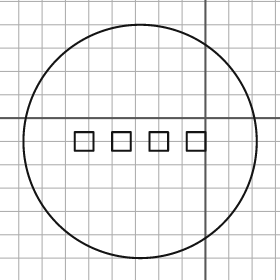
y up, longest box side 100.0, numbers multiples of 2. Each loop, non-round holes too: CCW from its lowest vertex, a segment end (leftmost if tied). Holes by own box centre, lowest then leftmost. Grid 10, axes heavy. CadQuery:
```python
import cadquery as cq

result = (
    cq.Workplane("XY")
    .moveTo(-28.0, -10.0)
    .circle(50.0)
    .moveTo(-56.0, -14.0)
    .lineTo(-48.0, -14.0)
    .lineTo(-48.0, -6.0)
    .lineTo(-56.0, -6.0)
    .close()
    .moveTo(-40.0, -14.0)
    .lineTo(-32.0, -14.0)
    .lineTo(-32.0, -6.0)
    .lineTo(-40.0, -6.0)
    .close()
    .moveTo(-24.0, -14.0)
    .lineTo(-16.0, -14.0)
    .lineTo(-16.0, -6.0)
    .lineTo(-24.0, -6.0)
    .close()
    .moveTo(-8.0, -14.0)
    .lineTo(0.0, -14.0)
    .lineTo(0.0, -6.0)
    .lineTo(-8.0, -6.0)
    .close()
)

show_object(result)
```